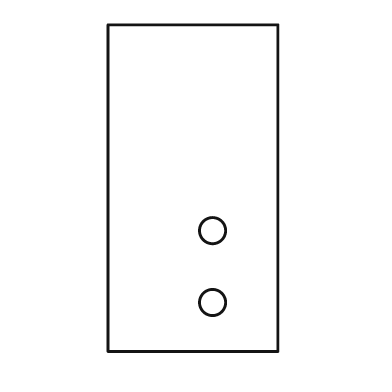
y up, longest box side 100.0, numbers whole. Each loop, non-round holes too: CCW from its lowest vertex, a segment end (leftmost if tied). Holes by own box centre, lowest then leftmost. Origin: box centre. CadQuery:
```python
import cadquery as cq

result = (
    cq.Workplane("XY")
    .moveTo(-26.0, -50.0)
    .lineTo(26.0, -50.0)
    .lineTo(26.0, 50.0)
    .lineTo(-26.0, 50.0)
    .close()
    .moveTo(6.0, -35.0)
    .circle(4.0)
    .moveTo(6.0, -13.0)
    .circle(4.0)
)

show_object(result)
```